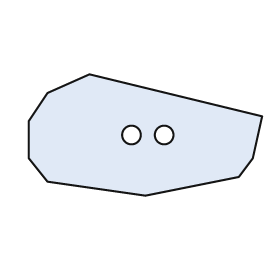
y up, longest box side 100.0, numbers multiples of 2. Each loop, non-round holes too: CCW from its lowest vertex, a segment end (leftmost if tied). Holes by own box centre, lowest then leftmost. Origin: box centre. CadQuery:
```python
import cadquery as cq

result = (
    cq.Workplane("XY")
    .moveTo(0.0, -26.0)
    .lineTo(40.0, -18.0)
    .lineTo(46.0, -10.0)
    .lineTo(50.0, 8.0)
    .lineTo(-24.0, 26.0)
    .lineTo(-42.0, 18.0)
    .lineTo(-50.0, 6.0)
    .lineTo(-50.0, -10.0)
    .lineTo(-42.0, -20.0)
    .close()
    .moveTo(-6.0, 0.0)
    .circle(4.0)
    .moveTo(8.0, 0.0)
    .circle(4.0)
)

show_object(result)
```